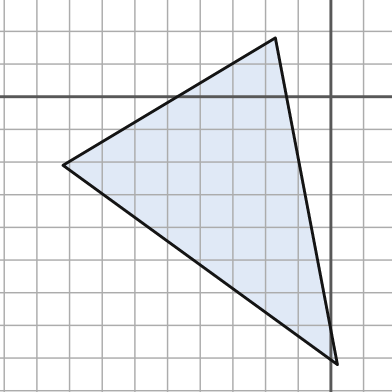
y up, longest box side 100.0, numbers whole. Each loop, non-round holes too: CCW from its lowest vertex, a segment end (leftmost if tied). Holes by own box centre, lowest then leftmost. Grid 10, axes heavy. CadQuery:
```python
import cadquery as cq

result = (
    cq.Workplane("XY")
    .moveTo(2.0, -82.0)
    .lineTo(-17.0, 18.0)
    .lineTo(-82.0, -21.0)
    .close()
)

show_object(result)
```